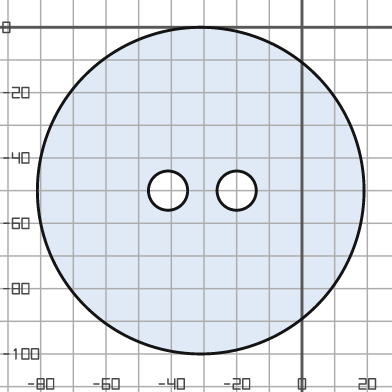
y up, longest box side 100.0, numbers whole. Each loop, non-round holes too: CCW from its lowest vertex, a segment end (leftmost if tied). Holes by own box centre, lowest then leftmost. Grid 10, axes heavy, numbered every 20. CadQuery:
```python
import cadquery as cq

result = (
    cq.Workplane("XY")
    .moveTo(-31.0, -50.0)
    .circle(50.0)
    .moveTo(-41.0, -50.0)
    .circle(6.0)
    .moveTo(-20.0, -50.0)
    .circle(6.0)
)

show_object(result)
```